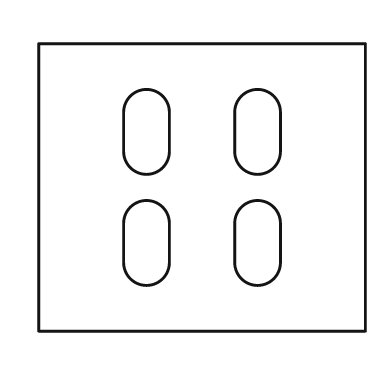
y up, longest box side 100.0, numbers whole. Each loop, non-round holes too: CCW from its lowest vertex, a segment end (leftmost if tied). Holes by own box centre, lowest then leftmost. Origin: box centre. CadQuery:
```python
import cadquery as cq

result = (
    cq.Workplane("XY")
    .moveTo(-50.0, -44.0)
    .lineTo(50.0, -44.0)
    .lineTo(50.0, 44.0)
    .lineTo(-50.0, 44.0)
    .close()
    .moveTo(-24.0, -23.0)
    .threePointArc((-17.0, -30.0), (-10.0, -23.0))
    .lineTo(-10.0, -11.0)
    .threePointArc((-17.0, -4.0), (-24.0, -11.0))
    .close()
    .moveTo(10.0, -23.0)
    .threePointArc((17.0, -30.0), (24.0, -23.0))
    .lineTo(24.0, -11.0)
    .threePointArc((17.0, -4.0), (10.0, -11.0))
    .close()
    .moveTo(-24.0, 11.0)
    .threePointArc((-17.0, 4.0), (-10.0, 11.0))
    .lineTo(-10.0, 23.0)
    .threePointArc((-17.0, 30.0), (-24.0, 23.0))
    .close()
    .moveTo(10.0, 11.0)
    .threePointArc((17.0, 4.0), (24.0, 11.0))
    .lineTo(24.0, 23.0)
    .threePointArc((17.0, 30.0), (10.0, 23.0))
    .close()
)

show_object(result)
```